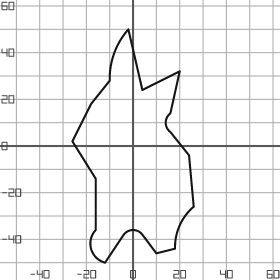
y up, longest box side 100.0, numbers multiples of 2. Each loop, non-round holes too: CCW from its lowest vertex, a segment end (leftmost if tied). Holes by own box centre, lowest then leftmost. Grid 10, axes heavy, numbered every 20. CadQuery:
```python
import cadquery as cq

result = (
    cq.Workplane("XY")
    .moveTo(-12.0, -50.0)
    .lineTo(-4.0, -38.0)
    .threePointArc((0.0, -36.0), (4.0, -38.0))
    .lineTo(10.0, -46.0)
    .lineTo(18.0, -44.0)
    .threePointArc((20.0, -34.0), (26.0, -26.0))
    .lineTo(24.0, -4.0)
    .lineTo(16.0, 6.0)
    .threePointArc((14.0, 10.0), (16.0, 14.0))
    .lineTo(20.0, 32.0)
    .lineTo(4.0, 24.0)
    .lineTo(-2.0, 50.0)
    .threePointArc((-8.0, 40.0), (-10.0, 28.0))
    .lineTo(-18.0, 18.0)
    .lineTo(-26.0, 2.0)
    .lineTo(-16.0, -14.0)
    .lineTo(-16.0, -36.0)
    .threePointArc((-18.0, -44.0), (-12.0, -50.0))
    .close()
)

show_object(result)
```